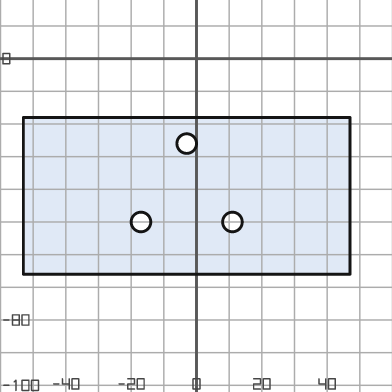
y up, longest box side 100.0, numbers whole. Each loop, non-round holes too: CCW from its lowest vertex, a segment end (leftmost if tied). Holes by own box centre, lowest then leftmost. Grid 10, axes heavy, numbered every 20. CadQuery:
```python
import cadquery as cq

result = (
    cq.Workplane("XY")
    .moveTo(-53.0, -66.0)
    .lineTo(47.0, -66.0)
    .lineTo(47.0, -18.0)
    .lineTo(-53.0, -18.0)
    .close()
    .moveTo(-17.0, -50.0)
    .circle(3.0)
    .moveTo(11.0, -50.0)
    .circle(3.0)
    .moveTo(-3.0, -26.0)
    .circle(3.0)
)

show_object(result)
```